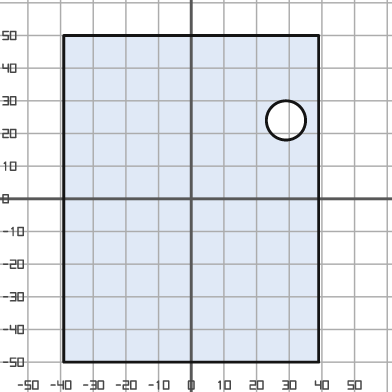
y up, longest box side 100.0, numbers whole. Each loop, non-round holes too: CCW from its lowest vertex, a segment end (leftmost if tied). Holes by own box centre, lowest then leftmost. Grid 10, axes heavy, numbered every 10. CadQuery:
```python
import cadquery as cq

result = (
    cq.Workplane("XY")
    .moveTo(-39.0, -50.0)
    .lineTo(39.0, -50.0)
    .lineTo(39.0, 50.0)
    .lineTo(-39.0, 50.0)
    .close()
    .moveTo(29.0, 24.0)
    .circle(6.0)
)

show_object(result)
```